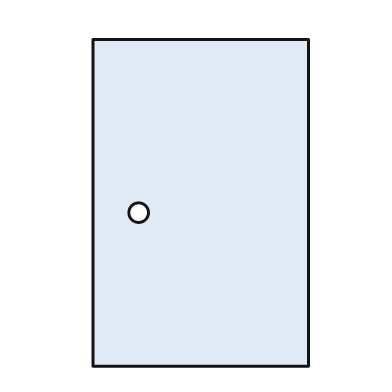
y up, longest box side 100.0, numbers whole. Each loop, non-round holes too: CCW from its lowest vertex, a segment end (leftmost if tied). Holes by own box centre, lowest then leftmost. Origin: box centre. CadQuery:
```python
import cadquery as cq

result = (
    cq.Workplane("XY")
    .moveTo(-33.0, -50.0)
    .lineTo(33.0, -50.0)
    .lineTo(33.0, 50.0)
    .lineTo(-33.0, 50.0)
    .close()
    .moveTo(-19.0, -3.0)
    .circle(3.0)
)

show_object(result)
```